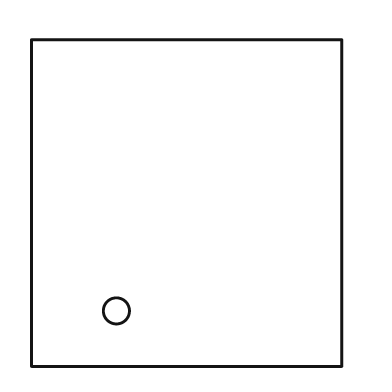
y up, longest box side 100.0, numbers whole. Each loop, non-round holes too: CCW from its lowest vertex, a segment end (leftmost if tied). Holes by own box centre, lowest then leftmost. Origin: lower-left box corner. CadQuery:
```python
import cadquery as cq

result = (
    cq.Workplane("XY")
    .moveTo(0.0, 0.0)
    .lineTo(95.0, 0.0)
    .lineTo(95.0, 100.0)
    .lineTo(0.0, 100.0)
    .close()
    .moveTo(26.0, 17.0)
    .circle(4.0)
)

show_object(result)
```